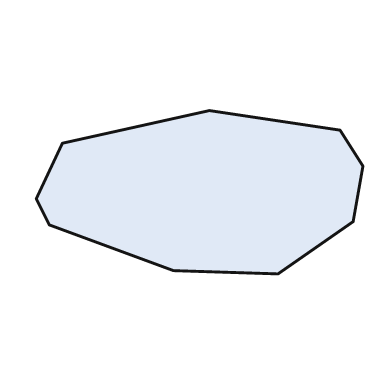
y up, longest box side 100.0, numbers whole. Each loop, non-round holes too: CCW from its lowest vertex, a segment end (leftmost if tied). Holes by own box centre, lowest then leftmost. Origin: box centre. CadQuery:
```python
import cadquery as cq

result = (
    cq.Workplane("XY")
    .moveTo(24.0, -25.0)
    .lineTo(47.0, -9.0)
    .lineTo(50.0, 8.0)
    .lineTo(43.0, 19.0)
    .lineTo(3.0, 25.0)
    .lineTo(-42.0, 15.0)
    .lineTo(-50.0, -2.0)
    .lineTo(-46.0, -10.0)
    .lineTo(-8.0, -24.0)
    .close()
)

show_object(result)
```